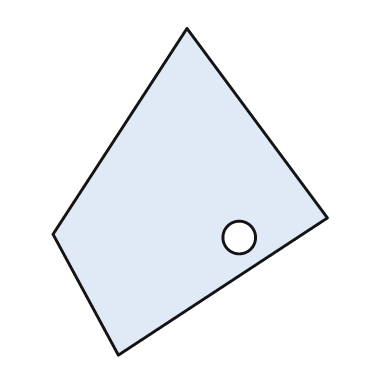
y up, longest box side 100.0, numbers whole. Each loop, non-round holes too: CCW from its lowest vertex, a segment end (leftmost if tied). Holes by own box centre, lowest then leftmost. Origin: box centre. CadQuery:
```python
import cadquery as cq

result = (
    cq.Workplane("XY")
    .moveTo(-22.0, -50.0)
    .lineTo(42.0, -8.0)
    .lineTo(-1.0, 50.0)
    .lineTo(-42.0, -13.0)
    .close()
    .moveTo(15.0, -14.0)
    .circle(5.0)
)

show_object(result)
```